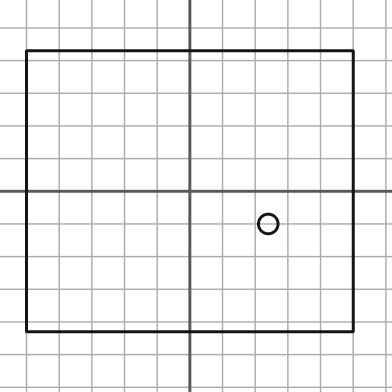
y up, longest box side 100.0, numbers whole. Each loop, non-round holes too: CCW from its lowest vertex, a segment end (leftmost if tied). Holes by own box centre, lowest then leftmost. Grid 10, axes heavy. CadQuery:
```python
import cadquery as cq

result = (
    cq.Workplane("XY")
    .moveTo(-50.0, -43.0)
    .lineTo(50.0, -43.0)
    .lineTo(50.0, 43.0)
    .lineTo(-50.0, 43.0)
    .close()
    .moveTo(24.0, -10.0)
    .circle(3.0)
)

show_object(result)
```